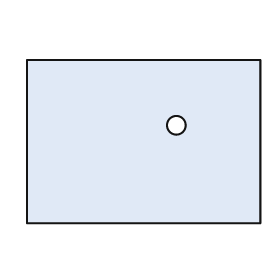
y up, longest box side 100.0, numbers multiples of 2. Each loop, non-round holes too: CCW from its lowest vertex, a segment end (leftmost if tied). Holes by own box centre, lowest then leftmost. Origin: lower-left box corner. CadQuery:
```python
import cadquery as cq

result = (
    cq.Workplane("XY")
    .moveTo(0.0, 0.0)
    .lineTo(100.0, 0.0)
    .lineTo(100.0, 70.0)
    .lineTo(0.0, 70.0)
    .close()
    .moveTo(64.0, 42.0)
    .circle(4.0)
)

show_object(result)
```